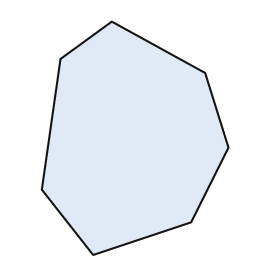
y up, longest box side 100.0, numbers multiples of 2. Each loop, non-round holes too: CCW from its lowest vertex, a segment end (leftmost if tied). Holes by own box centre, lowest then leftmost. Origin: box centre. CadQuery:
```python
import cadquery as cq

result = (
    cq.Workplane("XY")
    .moveTo(-18.0, -50.0)
    .lineTo(24.0, -36.0)
    .lineTo(40.0, -4.0)
    .lineTo(30.0, 28.0)
    .lineTo(-10.0, 50.0)
    .lineTo(-32.0, 34.0)
    .lineTo(-40.0, -22.0)
    .close()
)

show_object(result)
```